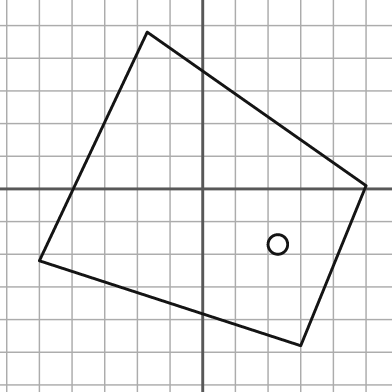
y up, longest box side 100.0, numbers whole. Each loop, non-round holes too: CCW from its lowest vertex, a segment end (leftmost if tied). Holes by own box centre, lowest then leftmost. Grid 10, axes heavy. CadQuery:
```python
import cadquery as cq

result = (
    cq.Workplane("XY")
    .moveTo(30.0, -48.0)
    .lineTo(50.0, 1.0)
    .lineTo(-17.0, 48.0)
    .lineTo(-50.0, -22.0)
    .close()
    .moveTo(23.0, -17.0)
    .circle(3.0)
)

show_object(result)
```